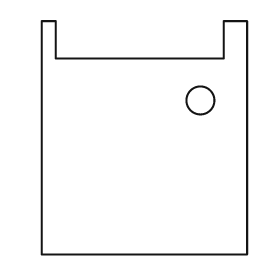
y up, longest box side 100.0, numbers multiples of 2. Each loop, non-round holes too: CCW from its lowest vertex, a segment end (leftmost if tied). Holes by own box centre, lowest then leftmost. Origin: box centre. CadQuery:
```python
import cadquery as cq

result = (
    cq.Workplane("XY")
    .moveTo(-44.0, -50.0)
    .lineTo(44.0, -50.0)
    .lineTo(44.0, 50.0)
    .lineTo(34.0, 50.0)
    .lineTo(34.0, 34.0)
    .lineTo(-38.0, 34.0)
    .lineTo(-38.0, 50.0)
    .lineTo(-44.0, 50.0)
    .close()
    .moveTo(24.0, 16.0)
    .circle(6.0)
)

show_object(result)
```